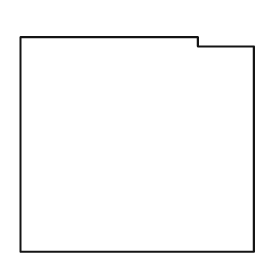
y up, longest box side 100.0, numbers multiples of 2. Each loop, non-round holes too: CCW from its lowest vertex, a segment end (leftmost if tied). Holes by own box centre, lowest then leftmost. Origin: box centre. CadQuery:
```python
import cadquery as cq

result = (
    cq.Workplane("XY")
    .moveTo(-50.0, -46.0)
    .lineTo(50.0, -46.0)
    .lineTo(50.0, 42.0)
    .lineTo(26.0, 42.0)
    .lineTo(26.0, 46.0)
    .lineTo(-50.0, 46.0)
    .close()
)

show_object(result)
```